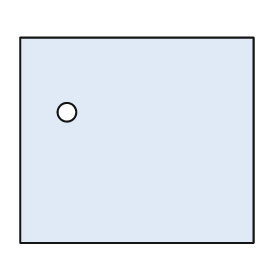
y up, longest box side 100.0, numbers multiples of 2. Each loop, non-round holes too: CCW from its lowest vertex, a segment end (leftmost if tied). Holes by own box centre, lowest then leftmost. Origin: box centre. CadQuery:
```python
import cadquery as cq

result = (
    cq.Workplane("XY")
    .moveTo(-50.0, -44.0)
    .lineTo(50.0, -44.0)
    .lineTo(50.0, 44.0)
    .lineTo(-50.0, 44.0)
    .close()
    .moveTo(-30.0, 12.0)
    .circle(4.0)
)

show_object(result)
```